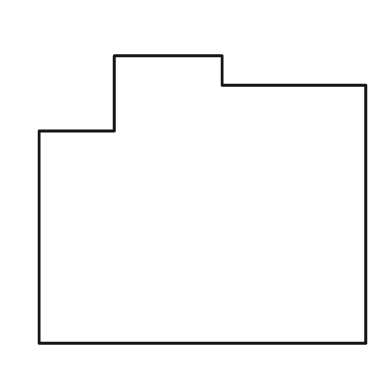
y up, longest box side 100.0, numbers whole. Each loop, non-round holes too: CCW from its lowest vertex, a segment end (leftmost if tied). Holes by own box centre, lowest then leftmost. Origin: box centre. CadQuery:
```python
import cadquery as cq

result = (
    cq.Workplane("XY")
    .moveTo(-50.0, -44.0)
    .lineTo(50.0, -44.0)
    .lineTo(50.0, 35.0)
    .lineTo(6.0, 35.0)
    .lineTo(6.0, 44.0)
    .lineTo(-27.0, 44.0)
    .lineTo(-27.0, 21.0)
    .lineTo(-50.0, 21.0)
    .close()
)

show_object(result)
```